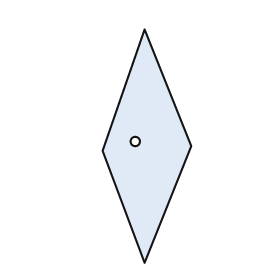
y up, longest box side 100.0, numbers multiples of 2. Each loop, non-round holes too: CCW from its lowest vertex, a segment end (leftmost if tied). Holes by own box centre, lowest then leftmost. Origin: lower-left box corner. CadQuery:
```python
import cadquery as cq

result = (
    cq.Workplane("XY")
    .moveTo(18.0, 0.0)
    .lineTo(38.0, 50.0)
    .lineTo(18.0, 100.0)
    .lineTo(0.0, 48.0)
    .close()
    .moveTo(14.0, 52.0)
    .circle(2.0)
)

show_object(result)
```